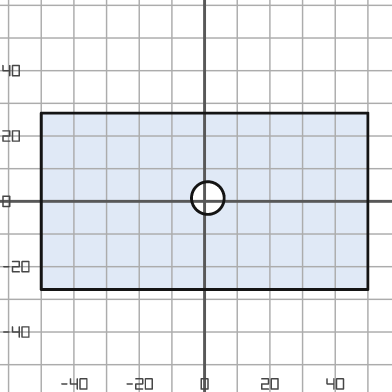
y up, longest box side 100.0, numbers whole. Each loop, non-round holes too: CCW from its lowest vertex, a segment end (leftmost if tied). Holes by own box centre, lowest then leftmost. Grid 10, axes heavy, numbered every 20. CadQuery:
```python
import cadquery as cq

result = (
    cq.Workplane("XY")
    .moveTo(-50.0, -27.0)
    .lineTo(50.0, -27.0)
    .lineTo(50.0, 27.0)
    .lineTo(-50.0, 27.0)
    .close()
    .moveTo(1.0, 1.0)
    .circle(5.0)
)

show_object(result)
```